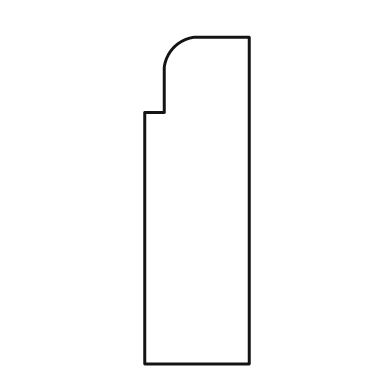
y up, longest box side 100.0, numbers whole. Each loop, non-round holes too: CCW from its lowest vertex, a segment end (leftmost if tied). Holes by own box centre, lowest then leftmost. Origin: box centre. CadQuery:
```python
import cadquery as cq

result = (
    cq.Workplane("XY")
    .moveTo(-16.0, -50.0)
    .lineTo(16.0, -50.0)
    .lineTo(16.0, 50.0)
    .lineTo(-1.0, 50.0)
    .threePointArc((-7.0, 47.0), (-10.0, 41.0))
    .lineTo(-10.0, 27.0)
    .lineTo(-16.0, 27.0)
    .close()
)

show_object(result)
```